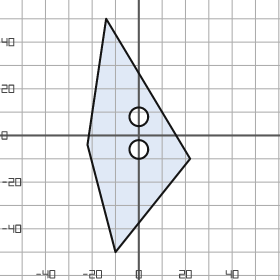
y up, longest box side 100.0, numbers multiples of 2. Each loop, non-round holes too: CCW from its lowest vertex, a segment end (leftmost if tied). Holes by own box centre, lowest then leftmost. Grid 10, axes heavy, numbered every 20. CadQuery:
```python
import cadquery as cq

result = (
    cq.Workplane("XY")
    .moveTo(-10.0, -50.0)
    .lineTo(22.0, -10.0)
    .lineTo(-14.0, 50.0)
    .lineTo(-22.0, -4.0)
    .close()
    .moveTo(0.0, -6.0)
    .circle(4.0)
    .moveTo(0.0, 8.0)
    .circle(4.0)
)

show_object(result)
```